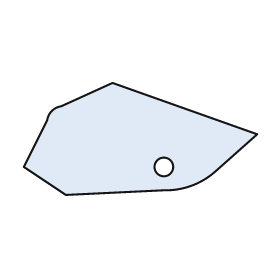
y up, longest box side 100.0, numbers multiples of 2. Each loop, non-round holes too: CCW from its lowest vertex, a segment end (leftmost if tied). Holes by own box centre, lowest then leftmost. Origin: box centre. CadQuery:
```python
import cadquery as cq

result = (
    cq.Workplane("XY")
    .moveTo(-32.0, -24.0)
    .lineTo(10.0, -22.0)
    .threePointArc((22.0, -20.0), (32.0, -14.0))
    .lineTo(50.0, 2.0)
    .lineTo(-12.0, 24.0)
    .lineTo(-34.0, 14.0)
    .threePointArc((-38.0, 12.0), (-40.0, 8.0))
    .lineTo(-50.0, -12.0)
    .close()
    .moveTo(10.0, -12.0)
    .circle(4.0)
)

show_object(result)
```